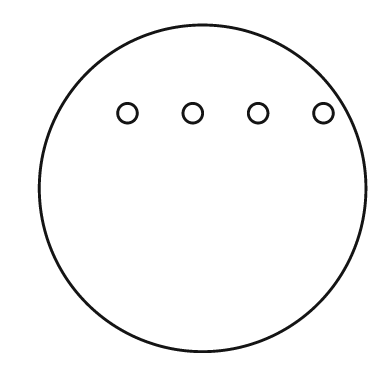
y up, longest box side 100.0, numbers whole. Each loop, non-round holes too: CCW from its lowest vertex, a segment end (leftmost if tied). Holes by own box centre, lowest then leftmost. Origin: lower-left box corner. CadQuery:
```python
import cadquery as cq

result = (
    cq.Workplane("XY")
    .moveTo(50.0, 50.0)
    .circle(50.0)
    .moveTo(27.0, 73.0)
    .circle(3.0)
    .moveTo(47.0, 73.0)
    .circle(3.0)
    .moveTo(67.0, 73.0)
    .circle(3.0)
    .moveTo(87.0, 73.0)
    .circle(3.0)
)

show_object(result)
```